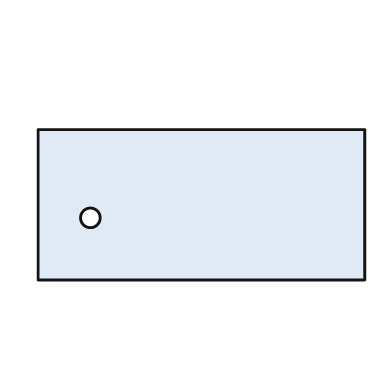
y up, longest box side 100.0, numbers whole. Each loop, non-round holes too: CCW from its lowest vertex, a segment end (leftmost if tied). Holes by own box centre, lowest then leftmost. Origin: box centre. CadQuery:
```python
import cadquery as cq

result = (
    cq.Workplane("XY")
    .moveTo(-50.0, -23.0)
    .lineTo(50.0, -23.0)
    .lineTo(50.0, 23.0)
    .lineTo(-50.0, 23.0)
    .close()
    .moveTo(-34.0, -4.0)
    .circle(3.0)
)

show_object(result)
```